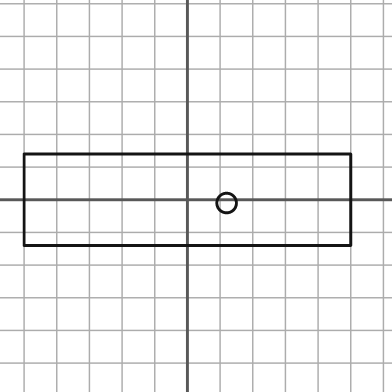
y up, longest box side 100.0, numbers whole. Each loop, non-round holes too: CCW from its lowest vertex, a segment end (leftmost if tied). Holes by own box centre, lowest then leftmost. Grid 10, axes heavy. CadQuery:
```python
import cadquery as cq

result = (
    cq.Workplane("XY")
    .moveTo(-50.0, -14.0)
    .lineTo(50.0, -14.0)
    .lineTo(50.0, 14.0)
    .lineTo(-50.0, 14.0)
    .close()
    .moveTo(12.0, -1.0)
    .circle(3.0)
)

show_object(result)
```